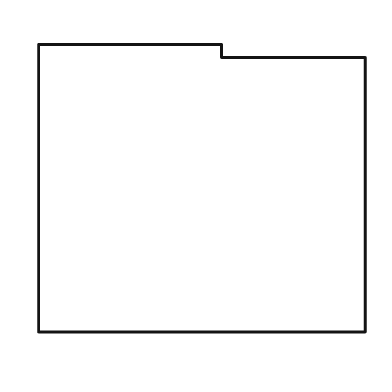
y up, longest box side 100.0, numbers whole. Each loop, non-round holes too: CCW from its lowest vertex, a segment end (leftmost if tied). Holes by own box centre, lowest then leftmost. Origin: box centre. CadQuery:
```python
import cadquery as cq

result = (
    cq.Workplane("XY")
    .moveTo(-50.0, -44.0)
    .lineTo(50.0, -44.0)
    .lineTo(50.0, 40.0)
    .lineTo(6.0, 40.0)
    .lineTo(6.0, 44.0)
    .lineTo(-50.0, 44.0)
    .close()
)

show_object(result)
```